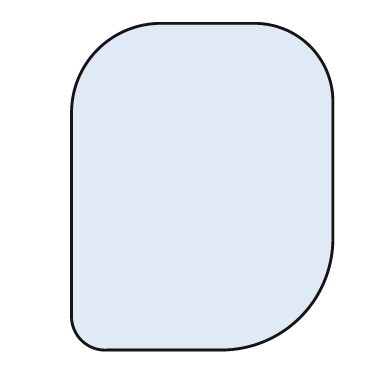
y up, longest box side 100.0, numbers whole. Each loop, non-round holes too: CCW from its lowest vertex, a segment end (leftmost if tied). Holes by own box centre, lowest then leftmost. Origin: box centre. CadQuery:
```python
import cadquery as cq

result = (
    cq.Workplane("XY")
    .moveTo(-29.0, -50.0)
    .lineTo(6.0, -50.0)
    .threePointArc((30.0, -40.0), (40.0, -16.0))
    .lineTo(40.0, 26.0)
    .threePointArc((33.0, 43.0), (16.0, 50.0))
    .lineTo(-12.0, 50.0)
    .threePointArc((-32.0, 42.0), (-40.0, 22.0))
    .lineTo(-40.0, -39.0)
    .threePointArc((-37.0, -47.0), (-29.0, -50.0))
    .close()
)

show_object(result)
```